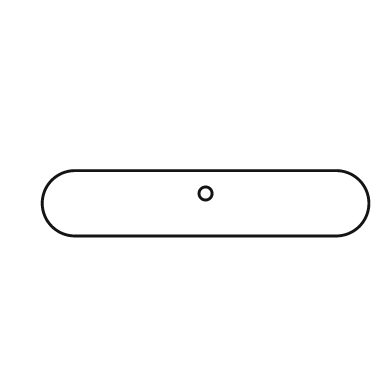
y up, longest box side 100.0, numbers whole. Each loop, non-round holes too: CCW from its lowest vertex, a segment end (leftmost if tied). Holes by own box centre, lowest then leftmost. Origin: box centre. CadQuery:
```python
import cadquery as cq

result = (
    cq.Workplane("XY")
    .moveTo(-40.0, -10.0)
    .lineTo(40.0, -10.0)
    .threePointArc((50.0, 0.0), (40.0, 10.0))
    .lineTo(-40.0, 10.0)
    .threePointArc((-50.0, 0.0), (-40.0, -10.0))
    .close()
    .moveTo(0.0, 3.0)
    .circle(2.0)
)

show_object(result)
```